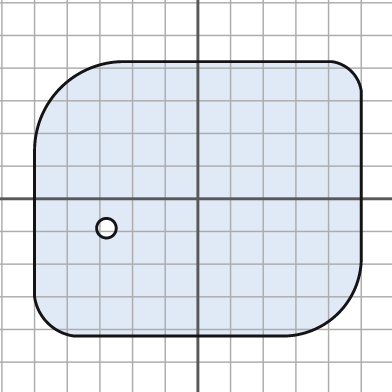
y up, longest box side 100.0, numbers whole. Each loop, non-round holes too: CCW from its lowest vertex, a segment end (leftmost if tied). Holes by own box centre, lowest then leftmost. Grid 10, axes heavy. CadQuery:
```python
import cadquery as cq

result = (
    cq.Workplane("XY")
    .moveTo(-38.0, -42.0)
    .lineTo(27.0, -42.0)
    .threePointArc((43.0, -35.0), (50.0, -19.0))
    .lineTo(50.0, 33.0)
    .threePointArc((47.0, 39.0), (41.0, 42.0))
    .lineTo(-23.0, 42.0)
    .threePointArc((-42.0, 34.0), (-50.0, 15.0))
    .lineTo(-50.0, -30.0)
    .threePointArc((-46.0, -38.0), (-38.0, -42.0))
    .close()
    .moveTo(-28.0, -9.0)
    .circle(3.0)
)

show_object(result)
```